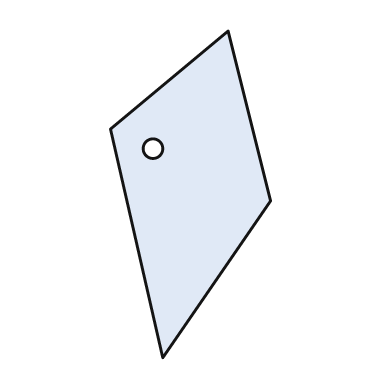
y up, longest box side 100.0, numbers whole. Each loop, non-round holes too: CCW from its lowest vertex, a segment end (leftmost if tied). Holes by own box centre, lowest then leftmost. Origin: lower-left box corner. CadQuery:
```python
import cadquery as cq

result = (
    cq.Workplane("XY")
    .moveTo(16.0, 0.0)
    .lineTo(49.0, 48.0)
    .lineTo(36.0, 100.0)
    .lineTo(0.0, 70.0)
    .close()
    .moveTo(13.0, 64.0)
    .circle(3.0)
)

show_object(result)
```